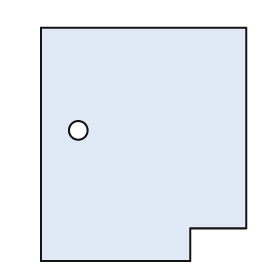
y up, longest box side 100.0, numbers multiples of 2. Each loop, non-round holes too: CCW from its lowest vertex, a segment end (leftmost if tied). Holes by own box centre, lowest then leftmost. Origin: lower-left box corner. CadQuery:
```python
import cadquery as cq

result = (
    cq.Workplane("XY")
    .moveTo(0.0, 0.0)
    .lineTo(64.0, 0.0)
    .lineTo(64.0, 14.0)
    .lineTo(88.0, 14.0)
    .lineTo(88.0, 100.0)
    .lineTo(0.0, 100.0)
    .close()
    .moveTo(16.0, 56.0)
    .circle(4.0)
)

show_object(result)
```